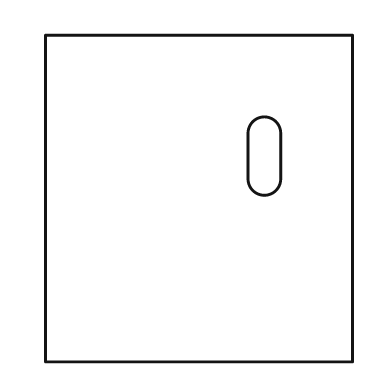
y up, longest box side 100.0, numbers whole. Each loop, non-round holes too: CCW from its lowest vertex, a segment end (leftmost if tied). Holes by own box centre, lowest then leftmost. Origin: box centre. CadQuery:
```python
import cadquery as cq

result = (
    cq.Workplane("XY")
    .moveTo(-47.0, -50.0)
    .lineTo(47.0, -50.0)
    .lineTo(47.0, 50.0)
    .lineTo(-47.0, 50.0)
    .close()
    .moveTo(15.0, 6.0)
    .threePointArc((20.0, 1.0), (25.0, 6.0))
    .lineTo(25.0, 20.0)
    .threePointArc((20.0, 25.0), (15.0, 20.0))
    .close()
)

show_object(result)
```